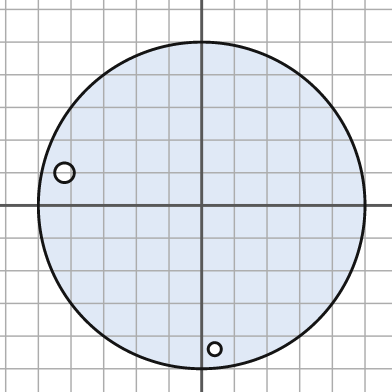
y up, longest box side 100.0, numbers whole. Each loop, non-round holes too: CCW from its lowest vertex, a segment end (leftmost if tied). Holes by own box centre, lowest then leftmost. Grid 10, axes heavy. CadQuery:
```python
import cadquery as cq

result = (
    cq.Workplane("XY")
    .moveTo(0.0, 0.0)
    .circle(50.0)
    .moveTo(4.0, -44.0)
    .circle(2.0)
    .moveTo(-42.0, 10.0)
    .circle(3.0)
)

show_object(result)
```